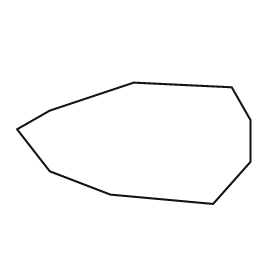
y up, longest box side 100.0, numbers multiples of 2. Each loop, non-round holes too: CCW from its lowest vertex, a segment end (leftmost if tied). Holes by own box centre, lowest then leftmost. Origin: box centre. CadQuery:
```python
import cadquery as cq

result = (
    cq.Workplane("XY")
    .moveTo(34.0, -26.0)
    .lineTo(50.0, -8.0)
    .lineTo(50.0, 10.0)
    .lineTo(42.0, 24.0)
    .lineTo(0.0, 26.0)
    .lineTo(-36.0, 14.0)
    .lineTo(-50.0, 6.0)
    .lineTo(-36.0, -12.0)
    .lineTo(-10.0, -22.0)
    .close()
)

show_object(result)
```